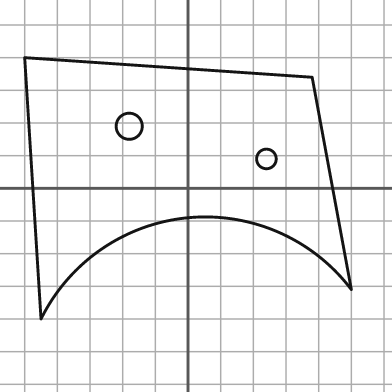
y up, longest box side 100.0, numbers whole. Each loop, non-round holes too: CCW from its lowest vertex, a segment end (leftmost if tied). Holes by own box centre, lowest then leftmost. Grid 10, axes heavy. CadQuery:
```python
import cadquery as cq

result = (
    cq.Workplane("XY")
    .moveTo(-45.0, -40.0)
    .threePointArc((0.0, -9.0), (50.0, -31.0))
    .lineTo(38.0, 34.0)
    .lineTo(-50.0, 40.0)
    .close()
    .moveTo(24.0, 9.0)
    .circle(3.0)
    .moveTo(-18.0, 19.0)
    .circle(4.0)
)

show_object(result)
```